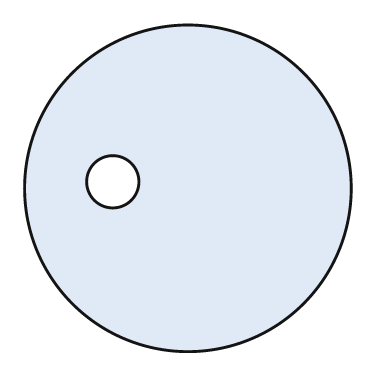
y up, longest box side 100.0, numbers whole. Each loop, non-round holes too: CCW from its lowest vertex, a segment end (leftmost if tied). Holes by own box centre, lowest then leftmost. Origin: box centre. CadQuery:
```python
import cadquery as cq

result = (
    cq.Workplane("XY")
    .moveTo(0.0, 0.0)
    .circle(50.0)
    .moveTo(-23.0, 2.0)
    .circle(8.0)
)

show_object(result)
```